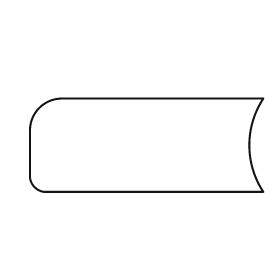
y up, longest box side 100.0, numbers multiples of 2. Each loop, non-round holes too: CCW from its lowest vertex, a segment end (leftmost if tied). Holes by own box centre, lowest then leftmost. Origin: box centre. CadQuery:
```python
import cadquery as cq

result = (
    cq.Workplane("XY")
    .moveTo(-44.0, -20.0)
    .lineTo(50.0, -20.0)
    .threePointArc((44.0, 0.0), (50.0, 20.0))
    .lineTo(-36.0, 20.0)
    .threePointArc((-46.0, 16.0), (-50.0, 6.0))
    .lineTo(-50.0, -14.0)
    .threePointArc((-48.0, -18.0), (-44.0, -20.0))
    .close()
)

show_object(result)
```